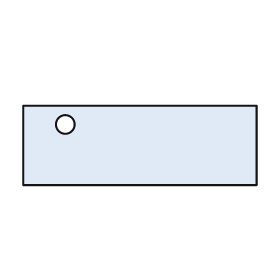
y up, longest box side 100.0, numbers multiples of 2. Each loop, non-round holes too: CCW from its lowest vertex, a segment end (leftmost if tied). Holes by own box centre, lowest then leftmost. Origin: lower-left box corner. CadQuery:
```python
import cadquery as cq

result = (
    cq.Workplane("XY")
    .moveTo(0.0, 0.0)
    .lineTo(100.0, 0.0)
    .lineTo(100.0, 34.0)
    .lineTo(0.0, 34.0)
    .close()
    .moveTo(18.0, 26.0)
    .circle(4.0)
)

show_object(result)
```